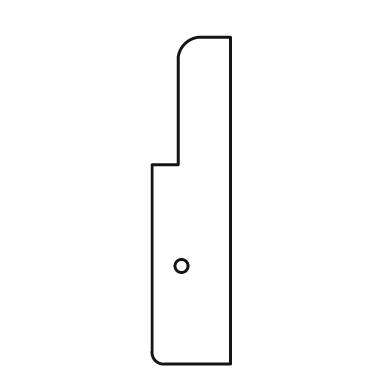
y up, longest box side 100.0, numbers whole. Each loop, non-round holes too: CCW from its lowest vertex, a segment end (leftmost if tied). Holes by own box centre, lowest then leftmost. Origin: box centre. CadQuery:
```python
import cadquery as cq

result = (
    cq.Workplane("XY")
    .moveTo(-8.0, -50.0)
    .lineTo(12.0, -50.0)
    .lineTo(12.0, 50.0)
    .lineTo(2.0, 50.0)
    .threePointArc((-2.0, 48.0), (-4.0, 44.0))
    .lineTo(-4.0, 11.0)
    .lineTo(-12.0, 11.0)
    .lineTo(-12.0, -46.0)
    .threePointArc((-11.0, -49.0), (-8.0, -50.0))
    .close()
    .moveTo(-3.0, -20.0)
    .circle(2.0)
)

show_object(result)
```